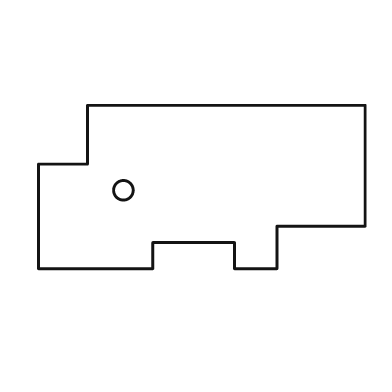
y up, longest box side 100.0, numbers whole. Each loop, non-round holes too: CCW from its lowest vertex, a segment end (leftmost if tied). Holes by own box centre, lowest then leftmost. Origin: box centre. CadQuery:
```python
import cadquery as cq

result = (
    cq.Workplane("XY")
    .moveTo(-50.0, -25.0)
    .lineTo(-15.0, -25.0)
    .lineTo(-15.0, -17.0)
    .lineTo(10.0, -17.0)
    .lineTo(10.0, -25.0)
    .lineTo(23.0, -25.0)
    .lineTo(23.0, -12.0)
    .lineTo(50.0, -12.0)
    .lineTo(50.0, 25.0)
    .lineTo(-35.0, 25.0)
    .lineTo(-35.0, 7.0)
    .lineTo(-50.0, 7.0)
    .close()
    .moveTo(-24.0, -1.0)
    .circle(3.0)
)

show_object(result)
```